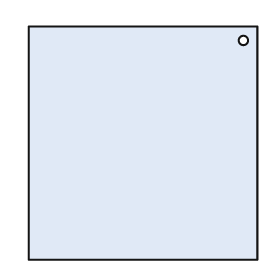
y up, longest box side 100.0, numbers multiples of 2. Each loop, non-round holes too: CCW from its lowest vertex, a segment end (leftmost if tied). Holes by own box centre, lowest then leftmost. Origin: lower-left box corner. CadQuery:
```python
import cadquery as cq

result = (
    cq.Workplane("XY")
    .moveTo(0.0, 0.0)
    .lineTo(98.0, 0.0)
    .lineTo(98.0, 100.0)
    .lineTo(0.0, 100.0)
    .close()
    .moveTo(92.0, 94.0)
    .circle(2.0)
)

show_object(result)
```